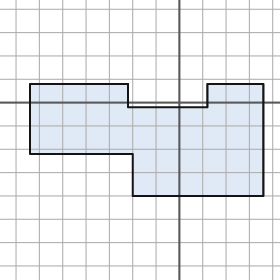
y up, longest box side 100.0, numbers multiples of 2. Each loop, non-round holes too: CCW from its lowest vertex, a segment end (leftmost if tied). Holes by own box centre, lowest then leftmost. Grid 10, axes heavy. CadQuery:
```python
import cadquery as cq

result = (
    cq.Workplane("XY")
    .moveTo(-20.0, -40.0)
    .lineTo(36.0, -40.0)
    .lineTo(36.0, 8.0)
    .lineTo(12.0, 8.0)
    .lineTo(12.0, -2.0)
    .lineTo(-22.0, -2.0)
    .lineTo(-22.0, 8.0)
    .lineTo(-64.0, 8.0)
    .lineTo(-64.0, -22.0)
    .lineTo(-20.0, -22.0)
    .close()
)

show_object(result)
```